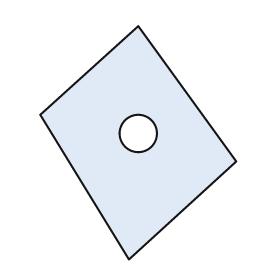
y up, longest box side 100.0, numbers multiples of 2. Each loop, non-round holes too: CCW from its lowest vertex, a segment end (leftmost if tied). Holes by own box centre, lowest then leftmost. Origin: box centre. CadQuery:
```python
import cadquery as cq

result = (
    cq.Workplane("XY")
    .moveTo(-4.0, -50.0)
    .lineTo(42.0, -8.0)
    .lineTo(0.0, 50.0)
    .lineTo(-42.0, 12.0)
    .close()
    .moveTo(0.0, 4.0)
    .circle(8.0)
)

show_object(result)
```